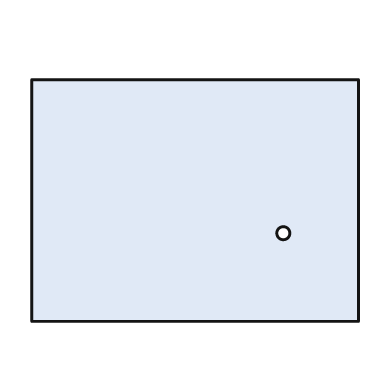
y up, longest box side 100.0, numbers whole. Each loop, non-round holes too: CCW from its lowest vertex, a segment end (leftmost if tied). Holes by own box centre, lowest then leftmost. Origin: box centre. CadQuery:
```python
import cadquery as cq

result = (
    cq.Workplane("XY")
    .moveTo(-50.0, -37.0)
    .lineTo(50.0, -37.0)
    .lineTo(50.0, 37.0)
    .lineTo(-50.0, 37.0)
    .close()
    .moveTo(27.0, -10.0)
    .circle(2.0)
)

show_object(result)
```